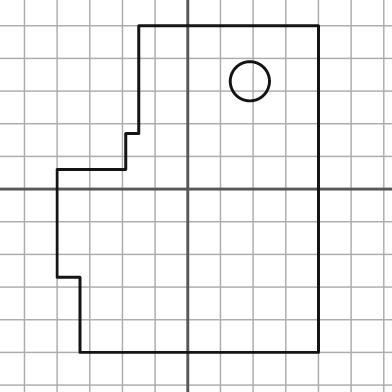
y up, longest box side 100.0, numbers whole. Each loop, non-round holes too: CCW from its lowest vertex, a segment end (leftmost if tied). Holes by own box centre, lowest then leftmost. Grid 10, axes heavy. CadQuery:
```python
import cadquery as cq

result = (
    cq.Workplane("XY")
    .moveTo(-33.0, -50.0)
    .lineTo(40.0, -50.0)
    .lineTo(40.0, 50.0)
    .lineTo(-15.0, 50.0)
    .lineTo(-15.0, 17.0)
    .lineTo(-19.0, 17.0)
    .lineTo(-19.0, 6.0)
    .lineTo(-40.0, 6.0)
    .lineTo(-40.0, -27.0)
    .lineTo(-33.0, -27.0)
    .close()
    .moveTo(19.0, 33.0)
    .circle(6.0)
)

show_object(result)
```